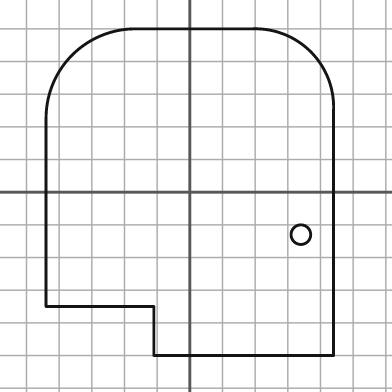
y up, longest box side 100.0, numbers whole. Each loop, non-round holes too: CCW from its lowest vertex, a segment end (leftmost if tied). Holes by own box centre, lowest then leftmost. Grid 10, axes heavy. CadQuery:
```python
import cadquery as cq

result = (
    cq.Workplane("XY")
    .moveTo(-11.0, -50.0)
    .lineTo(44.0, -50.0)
    .lineTo(44.0, 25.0)
    .threePointArc((37.0, 43.0), (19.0, 50.0))
    .lineTo(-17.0, 50.0)
    .threePointArc((-36.0, 42.0), (-44.0, 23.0))
    .lineTo(-44.0, -35.0)
    .lineTo(-11.0, -35.0)
    .close()
    .moveTo(34.0, -13.0)
    .circle(3.0)
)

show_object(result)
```